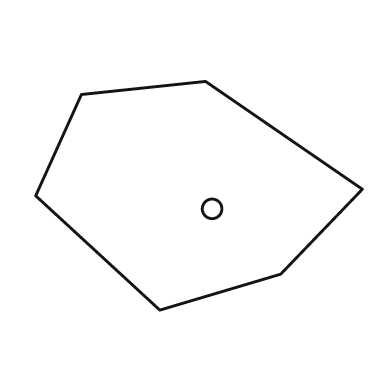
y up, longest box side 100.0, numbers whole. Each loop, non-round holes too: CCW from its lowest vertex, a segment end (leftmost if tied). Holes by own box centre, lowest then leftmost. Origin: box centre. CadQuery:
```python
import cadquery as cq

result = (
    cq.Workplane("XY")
    .moveTo(-12.0, -35.0)
    .lineTo(25.0, -24.0)
    .lineTo(50.0, 2.0)
    .lineTo(2.0, 35.0)
    .lineTo(-36.0, 31.0)
    .lineTo(-50.0, 0.0)
    .close()
    .moveTo(4.0, -4.0)
    .circle(3.0)
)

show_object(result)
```